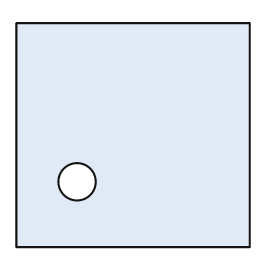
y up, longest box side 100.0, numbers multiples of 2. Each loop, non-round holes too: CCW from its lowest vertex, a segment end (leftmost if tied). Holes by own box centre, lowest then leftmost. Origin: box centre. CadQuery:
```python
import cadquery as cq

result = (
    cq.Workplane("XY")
    .moveTo(-50.0, -48.0)
    .lineTo(50.0, -48.0)
    .lineTo(50.0, 48.0)
    .lineTo(-50.0, 48.0)
    .close()
    .moveTo(-24.0, -20.0)
    .circle(8.0)
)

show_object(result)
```